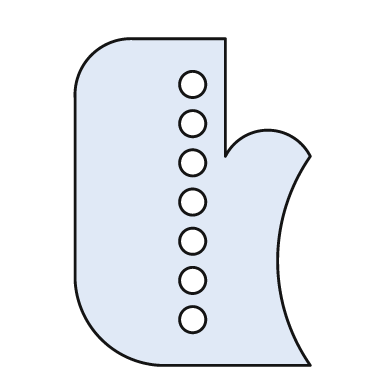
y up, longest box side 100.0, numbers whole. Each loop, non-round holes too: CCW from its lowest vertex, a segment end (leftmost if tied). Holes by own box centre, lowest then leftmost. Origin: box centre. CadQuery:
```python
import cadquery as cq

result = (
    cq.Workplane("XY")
    .moveTo(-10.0, -50.0)
    .lineTo(36.0, -50.0)
    .threePointArc((26.0, -18.0), (36.0, 14.0))
    .threePointArc((23.0, 22.0), (10.0, 14.0))
    .lineTo(10.0, 50.0)
    .lineTo(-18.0, 50.0)
    .threePointArc((-31.0, 45.0), (-36.0, 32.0))
    .lineTo(-36.0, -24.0)
    .threePointArc((-28.0, -42.0), (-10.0, -50.0))
    .close()
    .moveTo(0.0, -36.0)
    .circle(4.0)
    .moveTo(0.0, -24.0)
    .circle(4.0)
    .moveTo(0.0, -12.0)
    .circle(4.0)
    .moveTo(0.0, 0.0)
    .circle(4.0)
    .moveTo(0.0, 12.0)
    .circle(4.0)
    .moveTo(0.0, 24.0)
    .circle(4.0)
    .moveTo(0.0, 36.0)
    .circle(4.0)
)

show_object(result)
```